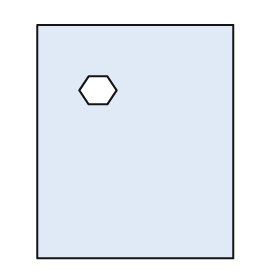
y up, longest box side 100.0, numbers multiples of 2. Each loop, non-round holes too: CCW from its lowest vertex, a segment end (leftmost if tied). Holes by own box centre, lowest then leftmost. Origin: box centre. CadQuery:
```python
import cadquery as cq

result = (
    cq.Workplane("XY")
    .moveTo(-42.0, -50.0)
    .lineTo(42.0, -50.0)
    .lineTo(42.0, 50.0)
    .lineTo(-42.0, 50.0)
    .close()
    .moveTo(-20.0, 16.0)
    .lineTo(-12.0, 16.0)
    .lineTo(-8.0, 22.0)
    .lineTo(-12.0, 28.0)
    .lineTo(-20.0, 28.0)
    .lineTo(-24.0, 22.0)
    .close()
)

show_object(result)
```